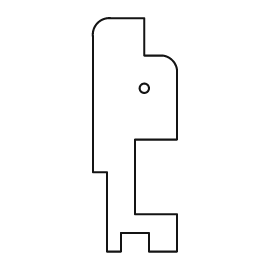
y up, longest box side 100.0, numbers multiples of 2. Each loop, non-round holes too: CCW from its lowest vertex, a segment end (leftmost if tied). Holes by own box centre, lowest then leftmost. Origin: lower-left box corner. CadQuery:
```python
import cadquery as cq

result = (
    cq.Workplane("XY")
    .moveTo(6.0, 0.0)
    .lineTo(12.0, 0.0)
    .lineTo(12.0, 8.0)
    .lineTo(24.0, 8.0)
    .lineTo(24.0, 0.0)
    .lineTo(36.0, 0.0)
    .lineTo(36.0, 16.0)
    .lineTo(18.0, 16.0)
    .lineTo(18.0, 48.0)
    .lineTo(36.0, 48.0)
    .lineTo(36.0, 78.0)
    .threePointArc((34.0, 82.0), (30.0, 84.0))
    .lineTo(22.0, 84.0)
    .lineTo(22.0, 100.0)
    .lineTo(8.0, 100.0)
    .threePointArc((2.0, 98.0), (0.0, 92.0))
    .lineTo(0.0, 34.0)
    .lineTo(6.0, 34.0)
    .close()
    .moveTo(22.0, 70.0)
    .circle(2.0)
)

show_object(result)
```